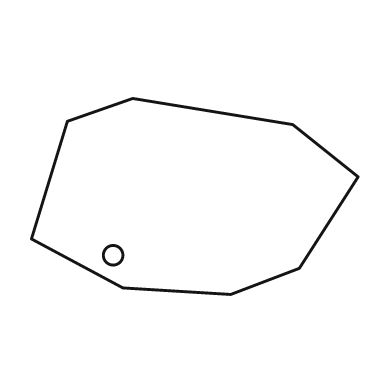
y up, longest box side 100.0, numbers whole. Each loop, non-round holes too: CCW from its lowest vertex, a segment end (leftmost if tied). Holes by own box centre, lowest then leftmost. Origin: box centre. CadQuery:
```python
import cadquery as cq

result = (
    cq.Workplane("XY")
    .moveTo(11.0, -30.0)
    .lineTo(32.0, -22.0)
    .lineTo(50.0, 6.0)
    .lineTo(30.0, 22.0)
    .lineTo(-19.0, 30.0)
    .lineTo(-39.0, 23.0)
    .lineTo(-50.0, -13.0)
    .lineTo(-22.0, -28.0)
    .close()
    .moveTo(-25.0, -18.0)
    .circle(3.0)
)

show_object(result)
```